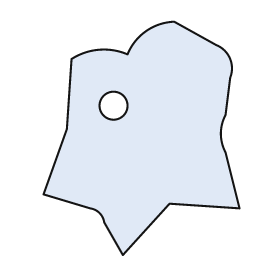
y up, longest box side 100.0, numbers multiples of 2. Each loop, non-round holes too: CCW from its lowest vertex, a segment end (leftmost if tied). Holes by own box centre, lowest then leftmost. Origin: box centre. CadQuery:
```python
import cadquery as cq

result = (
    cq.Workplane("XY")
    .moveTo(-8.0, -50.0)
    .lineTo(12.0, -28.0)
    .lineTo(42.0, -30.0)
    .lineTo(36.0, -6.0)
    .threePointArc((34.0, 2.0), (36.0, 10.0))
    .lineTo(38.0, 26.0)
    .threePointArc((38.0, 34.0), (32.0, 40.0))
    .lineTo(14.0, 50.0)
    .threePointArc((2.0, 46.0), (-6.0, 36.0))
    .threePointArc((-18.0, 38.0), (-30.0, 34.0))
    .lineTo(-32.0, 4.0)
    .lineTo(-42.0, -24.0)
    .lineTo(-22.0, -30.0)
    .threePointArc((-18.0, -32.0), (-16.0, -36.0))
    .close()
    .moveTo(-12.0, 14.0)
    .circle(6.0)
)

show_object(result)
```